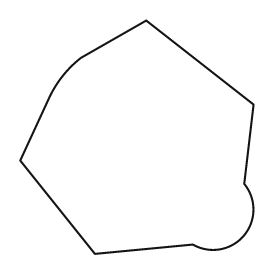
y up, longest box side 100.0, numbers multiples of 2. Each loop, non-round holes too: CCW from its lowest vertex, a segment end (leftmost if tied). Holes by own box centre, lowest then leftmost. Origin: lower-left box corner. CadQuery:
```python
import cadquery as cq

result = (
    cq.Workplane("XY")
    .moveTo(32.0, 0.0)
    .lineTo(74.0, 4.0)
    .threePointArc((96.0, 8.0), (96.0, 30.0))
    .lineTo(100.0, 64.0)
    .lineTo(54.0, 100.0)
    .lineTo(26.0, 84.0)
    .threePointArc((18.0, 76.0), (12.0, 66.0))
    .lineTo(0.0, 40.0)
    .close()
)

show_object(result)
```